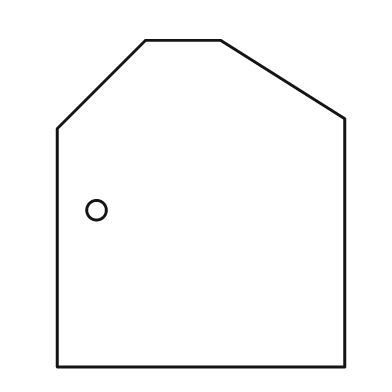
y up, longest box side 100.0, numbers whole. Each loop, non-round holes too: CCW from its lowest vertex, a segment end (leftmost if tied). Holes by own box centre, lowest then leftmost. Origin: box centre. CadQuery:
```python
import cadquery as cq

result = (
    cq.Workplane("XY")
    .moveTo(-44.0, -50.0)
    .lineTo(44.0, -50.0)
    .lineTo(44.0, 26.0)
    .lineTo(6.0, 50.0)
    .lineTo(-17.0, 50.0)
    .lineTo(-44.0, 23.0)
    .close()
    .moveTo(-32.0, -2.0)
    .circle(3.0)
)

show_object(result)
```